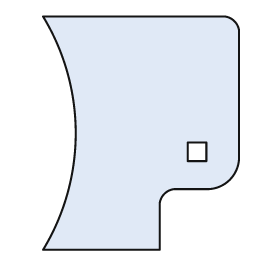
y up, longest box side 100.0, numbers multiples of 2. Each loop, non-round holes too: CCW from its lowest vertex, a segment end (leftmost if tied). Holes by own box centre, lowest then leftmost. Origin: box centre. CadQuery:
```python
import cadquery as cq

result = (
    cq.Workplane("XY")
    .moveTo(-42.0, -50.0)
    .lineTo(8.0, -50.0)
    .lineTo(8.0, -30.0)
    .threePointArc((10.0, -26.0), (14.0, -24.0))
    .lineTo(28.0, -24.0)
    .threePointArc((38.0, -20.0), (42.0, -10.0))
    .lineTo(42.0, 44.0)
    .threePointArc((40.0, 48.0), (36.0, 50.0))
    .lineTo(-42.0, 50.0)
    .threePointArc((-28.0, 0.0), (-42.0, -50.0))
    .close()
    .moveTo(20.0, -12.0)
    .lineTo(28.0, -12.0)
    .lineTo(28.0, -4.0)
    .lineTo(20.0, -4.0)
    .close()
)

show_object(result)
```